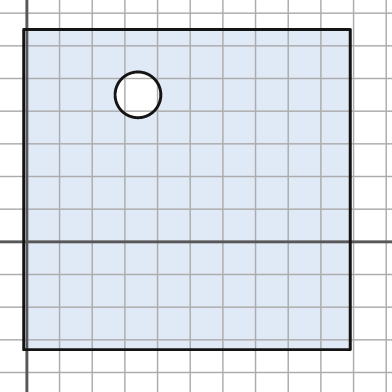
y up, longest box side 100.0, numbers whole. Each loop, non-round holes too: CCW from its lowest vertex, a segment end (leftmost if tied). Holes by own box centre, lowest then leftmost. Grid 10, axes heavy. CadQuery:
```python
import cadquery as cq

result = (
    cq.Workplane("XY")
    .moveTo(-1.0, -33.0)
    .lineTo(99.0, -33.0)
    .lineTo(99.0, 65.0)
    .lineTo(-1.0, 65.0)
    .close()
    .moveTo(34.0, 45.0)
    .circle(7.0)
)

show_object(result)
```